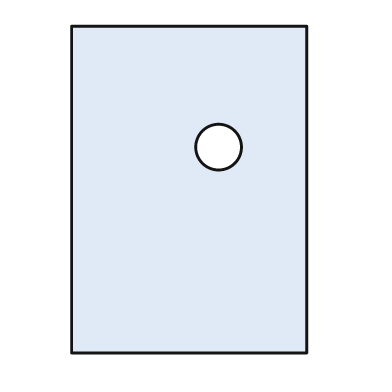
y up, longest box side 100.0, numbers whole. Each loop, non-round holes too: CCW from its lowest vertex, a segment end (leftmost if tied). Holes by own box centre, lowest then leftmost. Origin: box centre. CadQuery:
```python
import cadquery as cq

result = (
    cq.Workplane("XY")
    .moveTo(-36.0, -50.0)
    .lineTo(36.0, -50.0)
    .lineTo(36.0, 50.0)
    .lineTo(-36.0, 50.0)
    .close()
    .moveTo(9.0, 13.0)
    .circle(7.0)
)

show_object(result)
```